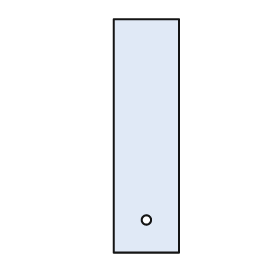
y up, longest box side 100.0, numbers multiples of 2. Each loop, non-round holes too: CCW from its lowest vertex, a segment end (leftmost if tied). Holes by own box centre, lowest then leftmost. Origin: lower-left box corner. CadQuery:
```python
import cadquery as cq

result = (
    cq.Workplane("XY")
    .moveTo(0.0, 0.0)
    .lineTo(28.0, 0.0)
    .lineTo(28.0, 100.0)
    .lineTo(0.0, 100.0)
    .close()
    .moveTo(14.0, 14.0)
    .circle(2.0)
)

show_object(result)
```